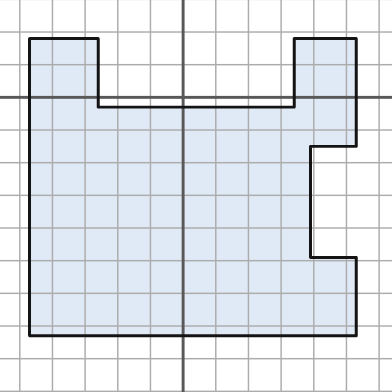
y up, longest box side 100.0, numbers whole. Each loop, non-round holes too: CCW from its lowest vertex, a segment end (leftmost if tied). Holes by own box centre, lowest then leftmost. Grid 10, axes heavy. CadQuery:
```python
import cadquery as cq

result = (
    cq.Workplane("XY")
    .moveTo(-47.0, -73.0)
    .lineTo(53.0, -73.0)
    .lineTo(53.0, -49.0)
    .lineTo(39.0, -49.0)
    .lineTo(39.0, -15.0)
    .lineTo(53.0, -15.0)
    .lineTo(53.0, 18.0)
    .lineTo(34.0, 18.0)
    .lineTo(34.0, -3.0)
    .lineTo(-26.0, -3.0)
    .lineTo(-26.0, 18.0)
    .lineTo(-47.0, 18.0)
    .close()
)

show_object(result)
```